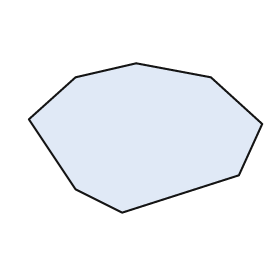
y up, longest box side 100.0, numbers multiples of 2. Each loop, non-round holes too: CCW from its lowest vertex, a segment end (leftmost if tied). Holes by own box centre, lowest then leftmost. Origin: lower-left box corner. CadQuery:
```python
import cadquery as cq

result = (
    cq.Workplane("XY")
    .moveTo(40.0, 0.0)
    .lineTo(90.0, 16.0)
    .lineTo(100.0, 38.0)
    .lineTo(78.0, 58.0)
    .lineTo(46.0, 64.0)
    .lineTo(20.0, 58.0)
    .lineTo(0.0, 40.0)
    .lineTo(20.0, 10.0)
    .close()
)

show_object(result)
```